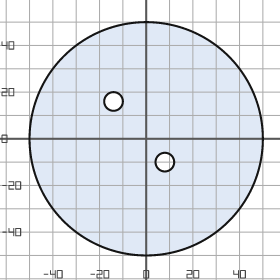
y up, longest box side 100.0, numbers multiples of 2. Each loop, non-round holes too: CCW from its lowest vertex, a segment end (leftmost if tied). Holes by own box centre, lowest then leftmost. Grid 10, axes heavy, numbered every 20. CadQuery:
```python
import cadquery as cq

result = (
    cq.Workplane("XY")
    .moveTo(0.0, 0.0)
    .circle(50.0)
    .moveTo(8.0, -10.0)
    .circle(4.0)
    .moveTo(-14.0, 16.0)
    .circle(4.0)
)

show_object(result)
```